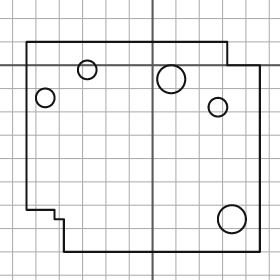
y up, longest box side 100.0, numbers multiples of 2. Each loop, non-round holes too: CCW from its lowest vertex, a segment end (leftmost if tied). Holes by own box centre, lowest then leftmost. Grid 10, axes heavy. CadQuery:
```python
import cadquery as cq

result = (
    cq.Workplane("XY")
    .moveTo(-38.0, -80.0)
    .lineTo(46.0, -80.0)
    .lineTo(46.0, 0.0)
    .lineTo(32.0, 0.0)
    .lineTo(32.0, 10.0)
    .lineTo(-54.0, 10.0)
    .lineTo(-54.0, -62.0)
    .lineTo(-42.0, -62.0)
    .lineTo(-42.0, -66.0)
    .lineTo(-38.0, -66.0)
    .close()
    .moveTo(34.0, -66.0)
    .circle(6.0)
    .moveTo(28.0, -18.0)
    .circle(4.0)
    .moveTo(-46.0, -14.0)
    .circle(4.0)
    .moveTo(8.0, -6.0)
    .circle(6.0)
    .moveTo(-28.0, -2.0)
    .circle(4.0)
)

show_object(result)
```